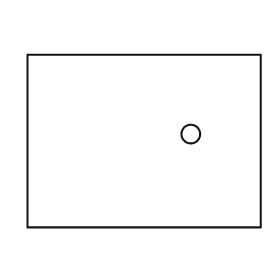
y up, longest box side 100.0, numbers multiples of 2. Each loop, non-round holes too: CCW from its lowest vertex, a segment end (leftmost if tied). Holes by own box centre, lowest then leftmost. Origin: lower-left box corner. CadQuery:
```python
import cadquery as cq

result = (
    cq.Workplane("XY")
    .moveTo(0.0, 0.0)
    .lineTo(100.0, 0.0)
    .lineTo(100.0, 74.0)
    .lineTo(0.0, 74.0)
    .close()
    .moveTo(70.0, 40.0)
    .circle(4.0)
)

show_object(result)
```